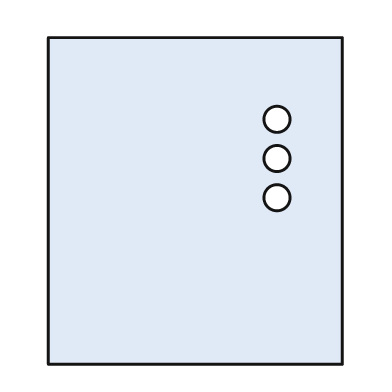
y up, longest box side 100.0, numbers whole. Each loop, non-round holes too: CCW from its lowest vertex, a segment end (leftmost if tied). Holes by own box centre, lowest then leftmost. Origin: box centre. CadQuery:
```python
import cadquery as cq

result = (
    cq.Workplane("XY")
    .moveTo(-45.0, -50.0)
    .lineTo(45.0, -50.0)
    .lineTo(45.0, 50.0)
    .lineTo(-45.0, 50.0)
    .close()
    .moveTo(25.0, 1.0)
    .circle(4.0)
    .moveTo(25.0, 13.0)
    .circle(4.0)
    .moveTo(25.0, 25.0)
    .circle(4.0)
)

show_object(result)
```